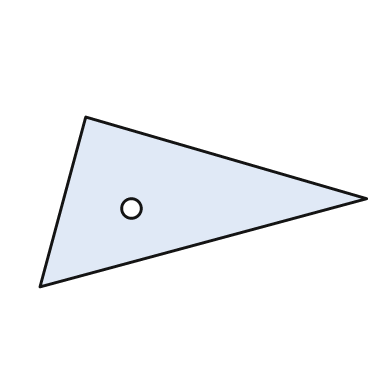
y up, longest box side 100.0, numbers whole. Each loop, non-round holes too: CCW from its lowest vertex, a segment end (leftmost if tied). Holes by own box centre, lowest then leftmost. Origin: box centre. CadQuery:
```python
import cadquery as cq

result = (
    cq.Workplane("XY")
    .moveTo(-50.0, -26.0)
    .lineTo(50.0, 1.0)
    .lineTo(-36.0, 26.0)
    .close()
    .moveTo(-22.0, -2.0)
    .circle(3.0)
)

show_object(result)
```